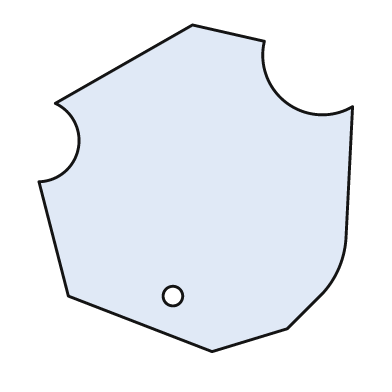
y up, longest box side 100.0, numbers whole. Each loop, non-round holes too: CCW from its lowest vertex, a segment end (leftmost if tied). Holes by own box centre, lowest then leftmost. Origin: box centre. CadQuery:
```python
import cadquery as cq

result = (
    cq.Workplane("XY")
    .moveTo(5.0, -50.0)
    .lineTo(28.0, -43.0)
    .lineTo(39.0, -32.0)
    .threePointArc((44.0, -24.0), (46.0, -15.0))
    .lineTo(48.0, 25.0)
    .threePointArc((28.0, 26.0), (21.0, 45.0))
    .lineTo(-1.0, 50.0)
    .lineTo(-43.0, 26.0)
    .threePointArc((-36.0, 12.0), (-48.0, 2.0))
    .lineTo(-39.0, -33.0)
    .close()
    .moveTo(-7.0, -33.0)
    .circle(3.0)
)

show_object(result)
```